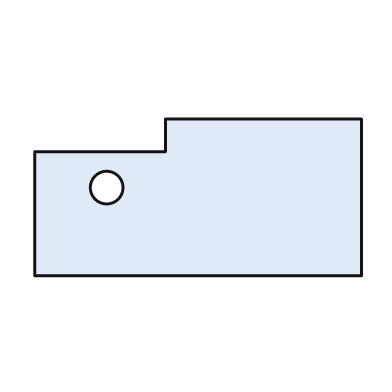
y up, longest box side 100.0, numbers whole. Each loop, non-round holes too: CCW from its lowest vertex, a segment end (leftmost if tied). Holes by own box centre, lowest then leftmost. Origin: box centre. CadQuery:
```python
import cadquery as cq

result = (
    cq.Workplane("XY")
    .moveTo(-50.0, -24.0)
    .lineTo(50.0, -24.0)
    .lineTo(50.0, 24.0)
    .lineTo(-10.0, 24.0)
    .lineTo(-10.0, 14.0)
    .lineTo(-50.0, 14.0)
    .close()
    .moveTo(-28.0, 3.0)
    .circle(5.0)
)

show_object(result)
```